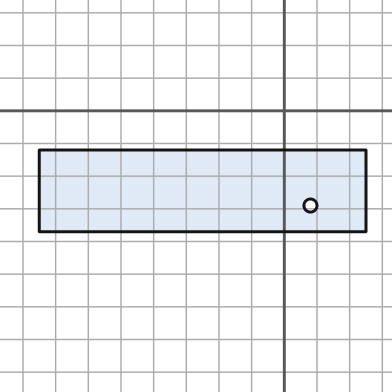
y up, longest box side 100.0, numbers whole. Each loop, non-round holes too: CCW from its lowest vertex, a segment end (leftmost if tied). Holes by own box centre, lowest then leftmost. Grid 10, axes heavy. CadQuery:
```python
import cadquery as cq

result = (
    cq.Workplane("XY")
    .moveTo(-75.0, -37.0)
    .lineTo(25.0, -37.0)
    .lineTo(25.0, -12.0)
    .lineTo(-75.0, -12.0)
    .close()
    .moveTo(8.0, -29.0)
    .circle(2.0)
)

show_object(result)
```